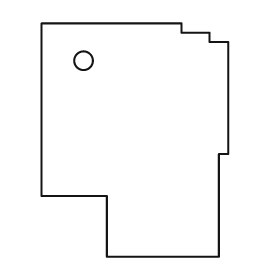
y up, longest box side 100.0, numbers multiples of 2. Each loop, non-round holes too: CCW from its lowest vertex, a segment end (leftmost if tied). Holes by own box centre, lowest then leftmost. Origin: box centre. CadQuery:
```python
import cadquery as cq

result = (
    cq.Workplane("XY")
    .moveTo(-12.0, -50.0)
    .lineTo(36.0, -50.0)
    .lineTo(36.0, -6.0)
    .lineTo(40.0, -6.0)
    .lineTo(40.0, 42.0)
    .lineTo(32.0, 42.0)
    .lineTo(32.0, 46.0)
    .lineTo(20.0, 46.0)
    .lineTo(20.0, 50.0)
    .lineTo(-40.0, 50.0)
    .lineTo(-40.0, -24.0)
    .lineTo(-12.0, -24.0)
    .close()
    .moveTo(-22.0, 34.0)
    .circle(4.0)
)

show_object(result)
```